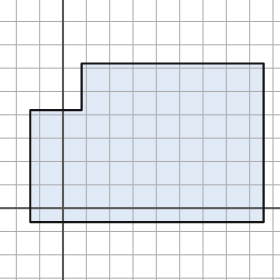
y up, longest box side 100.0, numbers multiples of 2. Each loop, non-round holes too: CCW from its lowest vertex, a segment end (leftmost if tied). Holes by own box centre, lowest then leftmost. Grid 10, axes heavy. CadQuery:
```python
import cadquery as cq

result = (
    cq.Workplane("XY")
    .moveTo(-14.0, -6.0)
    .lineTo(86.0, -6.0)
    .lineTo(86.0, 62.0)
    .lineTo(8.0, 62.0)
    .lineTo(8.0, 42.0)
    .lineTo(-14.0, 42.0)
    .close()
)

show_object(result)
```